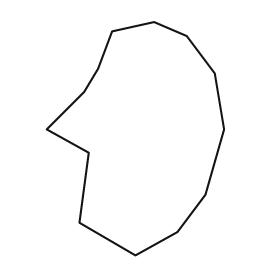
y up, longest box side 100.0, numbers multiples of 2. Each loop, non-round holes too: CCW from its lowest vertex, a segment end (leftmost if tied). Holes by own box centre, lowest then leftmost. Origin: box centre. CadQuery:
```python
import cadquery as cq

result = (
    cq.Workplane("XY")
    .moveTo(0.0, -50.0)
    .lineTo(18.0, -40.0)
    .lineTo(30.0, -24.0)
    .lineTo(38.0, 4.0)
    .lineTo(34.0, 28.0)
    .lineTo(22.0, 44.0)
    .lineTo(8.0, 50.0)
    .lineTo(-10.0, 46.0)
    .lineTo(-16.0, 30.0)
    .lineTo(-22.0, 20.0)
    .lineTo(-38.0, 4.0)
    .lineTo(-20.0, -6.0)
    .lineTo(-24.0, -36.0)
    .close()
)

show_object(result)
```